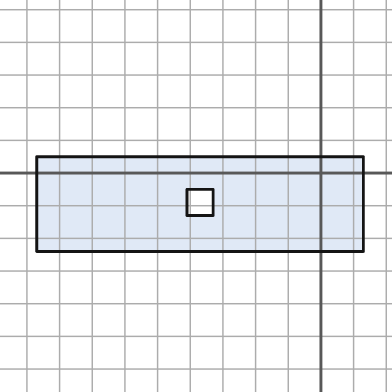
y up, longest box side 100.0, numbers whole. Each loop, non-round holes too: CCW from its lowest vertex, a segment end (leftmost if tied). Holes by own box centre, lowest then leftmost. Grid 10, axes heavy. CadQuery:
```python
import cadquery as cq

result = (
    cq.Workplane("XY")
    .moveTo(-87.0, -24.0)
    .lineTo(13.0, -24.0)
    .lineTo(13.0, 5.0)
    .lineTo(-87.0, 5.0)
    .close()
    .moveTo(-41.0, -13.0)
    .lineTo(-33.0, -13.0)
    .lineTo(-33.0, -5.0)
    .lineTo(-41.0, -5.0)
    .close()
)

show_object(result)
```